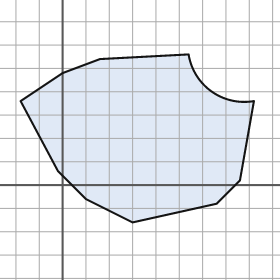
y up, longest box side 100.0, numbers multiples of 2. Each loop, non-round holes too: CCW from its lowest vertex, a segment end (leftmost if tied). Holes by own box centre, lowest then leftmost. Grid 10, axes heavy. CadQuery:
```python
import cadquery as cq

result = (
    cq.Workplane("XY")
    .moveTo(30.0, -16.0)
    .lineTo(66.0, -8.0)
    .lineTo(76.0, 2.0)
    .lineTo(82.0, 36.0)
    .threePointArc((64.0, 40.0), (54.0, 56.0))
    .lineTo(16.0, 54.0)
    .lineTo(0.0, 48.0)
    .lineTo(-18.0, 36.0)
    .lineTo(-2.0, 6.0)
    .lineTo(10.0, -6.0)
    .close()
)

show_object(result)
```